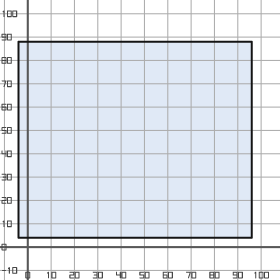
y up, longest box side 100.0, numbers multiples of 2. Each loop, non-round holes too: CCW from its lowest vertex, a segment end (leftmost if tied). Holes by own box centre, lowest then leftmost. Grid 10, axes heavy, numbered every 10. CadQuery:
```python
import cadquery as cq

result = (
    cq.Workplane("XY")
    .moveTo(-4.0, 4.0)
    .lineTo(96.0, 4.0)
    .lineTo(96.0, 88.0)
    .lineTo(-4.0, 88.0)
    .close()
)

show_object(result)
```